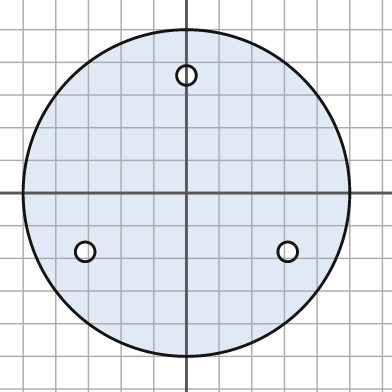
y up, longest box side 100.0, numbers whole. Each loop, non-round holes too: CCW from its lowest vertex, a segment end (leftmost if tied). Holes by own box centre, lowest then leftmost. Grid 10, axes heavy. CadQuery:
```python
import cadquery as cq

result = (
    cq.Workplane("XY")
    .moveTo(0.0, 0.0)
    .circle(50.0)
    .moveTo(-31.0, -18.0)
    .circle(3.0)
    .moveTo(31.0, -18.0)
    .circle(3.0)
    .moveTo(0.0, 36.0)
    .circle(3.0)
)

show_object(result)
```